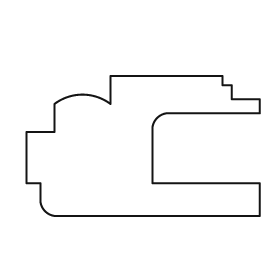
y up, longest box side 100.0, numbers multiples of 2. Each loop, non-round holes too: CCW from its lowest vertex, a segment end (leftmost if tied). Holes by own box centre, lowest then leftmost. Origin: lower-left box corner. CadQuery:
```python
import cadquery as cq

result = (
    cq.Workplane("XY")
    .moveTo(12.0, 0.0)
    .lineTo(100.0, 0.0)
    .lineTo(100.0, 14.0)
    .lineTo(54.0, 14.0)
    .lineTo(54.0, 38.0)
    .threePointArc((56.0, 42.0), (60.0, 44.0))
    .lineTo(100.0, 44.0)
    .lineTo(100.0, 50.0)
    .lineTo(88.0, 50.0)
    .lineTo(88.0, 56.0)
    .lineTo(84.0, 56.0)
    .lineTo(84.0, 60.0)
    .lineTo(36.0, 60.0)
    .lineTo(36.0, 48.0)
    .threePointArc((24.0, 52.0), (12.0, 48.0))
    .lineTo(12.0, 36.0)
    .lineTo(0.0, 36.0)
    .lineTo(0.0, 14.0)
    .lineTo(6.0, 14.0)
    .lineTo(6.0, 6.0)
    .threePointArc((8.0, 2.0), (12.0, 0.0))
    .close()
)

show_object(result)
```